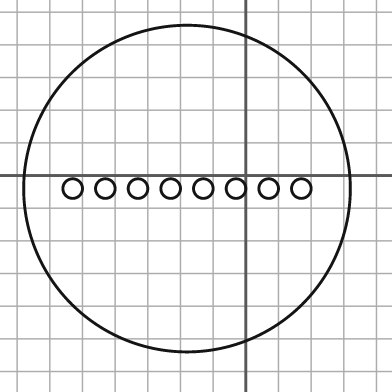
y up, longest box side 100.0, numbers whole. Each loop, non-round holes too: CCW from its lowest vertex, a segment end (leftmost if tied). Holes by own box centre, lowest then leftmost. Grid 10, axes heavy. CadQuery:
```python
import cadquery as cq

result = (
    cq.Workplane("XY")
    .moveTo(-18.0, -4.0)
    .circle(50.0)
    .moveTo(-53.0, -4.0)
    .circle(3.0)
    .moveTo(-43.0, -4.0)
    .circle(3.0)
    .moveTo(-33.0, -4.0)
    .circle(3.0)
    .moveTo(-23.0, -4.0)
    .circle(3.0)
    .moveTo(-13.0, -4.0)
    .circle(3.0)
    .moveTo(-3.0, -4.0)
    .circle(3.0)
    .moveTo(7.0, -4.0)
    .circle(3.0)
    .moveTo(17.0, -4.0)
    .circle(3.0)
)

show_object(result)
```